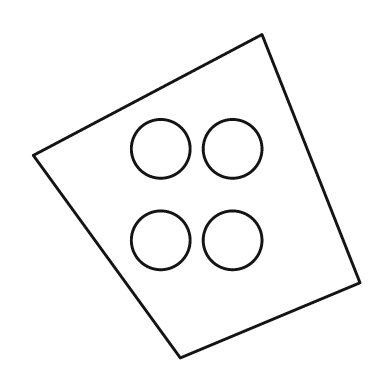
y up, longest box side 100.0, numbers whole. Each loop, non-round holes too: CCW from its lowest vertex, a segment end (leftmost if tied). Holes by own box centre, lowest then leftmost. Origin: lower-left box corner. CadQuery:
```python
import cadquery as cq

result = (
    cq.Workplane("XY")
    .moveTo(45.0, 0.0)
    .lineTo(100.0, 23.0)
    .lineTo(70.0, 99.0)
    .lineTo(0.0, 62.0)
    .close()
    .moveTo(39.0, 36.0)
    .circle(9.0)
    .moveTo(61.0, 36.0)
    .circle(9.0)
    .moveTo(39.0, 64.0)
    .circle(9.0)
    .moveTo(61.0, 64.0)
    .circle(9.0)
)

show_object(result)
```